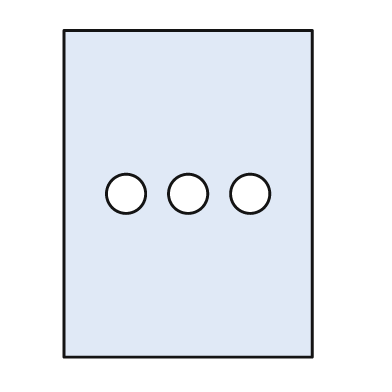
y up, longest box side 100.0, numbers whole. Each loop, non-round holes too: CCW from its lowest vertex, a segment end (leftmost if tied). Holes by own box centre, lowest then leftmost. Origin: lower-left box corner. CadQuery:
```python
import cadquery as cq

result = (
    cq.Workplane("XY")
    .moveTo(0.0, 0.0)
    .lineTo(76.0, 0.0)
    .lineTo(76.0, 100.0)
    .lineTo(0.0, 100.0)
    .close()
    .moveTo(19.0, 50.0)
    .circle(6.0)
    .moveTo(38.0, 50.0)
    .circle(6.0)
    .moveTo(57.0, 50.0)
    .circle(6.0)
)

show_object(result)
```